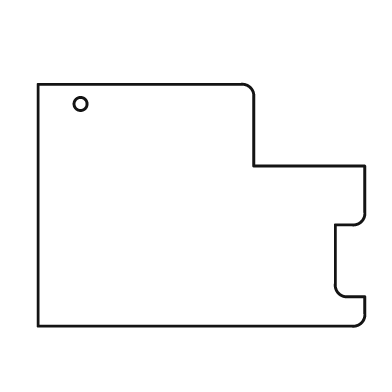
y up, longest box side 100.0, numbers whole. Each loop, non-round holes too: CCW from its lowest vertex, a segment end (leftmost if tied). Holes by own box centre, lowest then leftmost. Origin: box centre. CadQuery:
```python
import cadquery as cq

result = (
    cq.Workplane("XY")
    .moveTo(-50.0, -37.0)
    .lineTo(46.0, -37.0)
    .threePointArc((49.0, -36.0), (50.0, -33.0))
    .lineTo(50.0, -28.0)
    .lineTo(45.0, -28.0)
    .threePointArc((42.0, -27.0), (41.0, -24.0))
    .lineTo(41.0, -6.0)
    .lineTo(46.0, -6.0)
    .threePointArc((49.0, -5.0), (50.0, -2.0))
    .lineTo(50.0, 12.0)
    .lineTo(16.0, 12.0)
    .lineTo(16.0, 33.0)
    .threePointArc((15.0, 36.0), (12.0, 37.0))
    .lineTo(-50.0, 37.0)
    .close()
    .moveTo(-37.0, 31.0)
    .circle(2.0)
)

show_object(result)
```